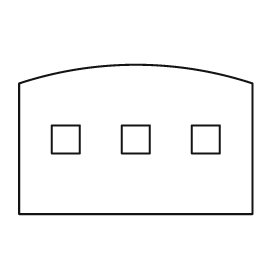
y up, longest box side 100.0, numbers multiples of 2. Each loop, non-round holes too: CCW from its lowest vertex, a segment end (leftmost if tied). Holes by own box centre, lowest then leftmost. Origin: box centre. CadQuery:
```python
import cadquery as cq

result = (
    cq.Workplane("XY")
    .moveTo(-50.0, -32.0)
    .lineTo(50.0, -32.0)
    .lineTo(50.0, 24.0)
    .threePointArc((0.0, 32.0), (-50.0, 24.0))
    .close()
    .moveTo(-36.0, -6.0)
    .lineTo(-24.0, -6.0)
    .lineTo(-24.0, 6.0)
    .lineTo(-36.0, 6.0)
    .close()
    .moveTo(-6.0, -6.0)
    .lineTo(6.0, -6.0)
    .lineTo(6.0, 6.0)
    .lineTo(-6.0, 6.0)
    .close()
    .moveTo(24.0, -6.0)
    .lineTo(36.0, -6.0)
    .lineTo(36.0, 6.0)
    .lineTo(24.0, 6.0)
    .close()
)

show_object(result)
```